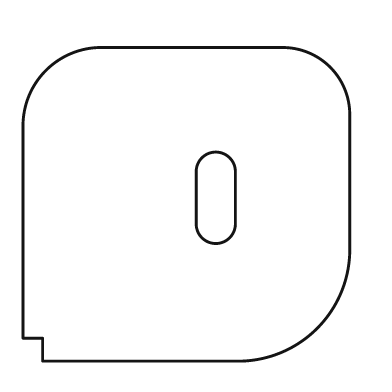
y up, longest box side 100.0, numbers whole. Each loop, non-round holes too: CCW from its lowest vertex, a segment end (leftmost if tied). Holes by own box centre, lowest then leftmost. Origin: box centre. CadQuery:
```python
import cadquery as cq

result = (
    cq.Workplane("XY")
    .moveTo(-44.0, -48.0)
    .lineTo(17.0, -48.0)
    .threePointArc((40.0, -38.0), (50.0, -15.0))
    .lineTo(50.0, 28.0)
    .threePointArc((44.0, 42.0), (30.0, 48.0))
    .lineTo(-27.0, 48.0)
    .threePointArc((-43.0, 41.0), (-50.0, 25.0))
    .lineTo(-50.0, -41.0)
    .lineTo(-44.0, -41.0)
    .close()
    .moveTo(3.0, -6.0)
    .threePointArc((9.0, -12.0), (15.0, -6.0))
    .lineTo(15.0, 10.0)
    .threePointArc((9.0, 16.0), (3.0, 10.0))
    .close()
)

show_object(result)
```